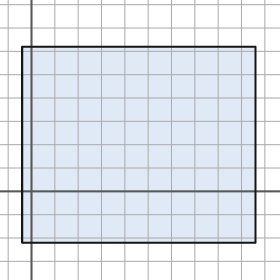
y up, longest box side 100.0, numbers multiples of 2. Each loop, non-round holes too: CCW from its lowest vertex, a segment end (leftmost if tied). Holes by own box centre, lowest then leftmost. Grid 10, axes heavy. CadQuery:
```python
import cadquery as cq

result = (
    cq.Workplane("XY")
    .moveTo(-4.0, -22.0)
    .lineTo(96.0, -22.0)
    .lineTo(96.0, 62.0)
    .lineTo(-4.0, 62.0)
    .close()
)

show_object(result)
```